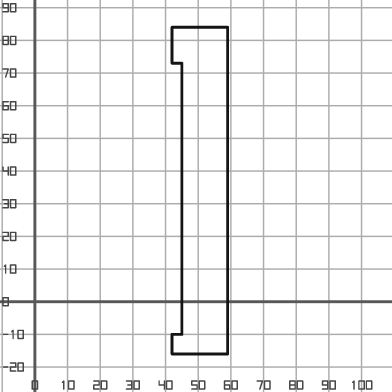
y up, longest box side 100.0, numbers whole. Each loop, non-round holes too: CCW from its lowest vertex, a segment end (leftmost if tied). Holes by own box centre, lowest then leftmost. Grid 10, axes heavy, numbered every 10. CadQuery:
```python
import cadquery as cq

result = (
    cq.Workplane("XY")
    .moveTo(42.0, -16.0)
    .lineTo(59.0, -16.0)
    .lineTo(59.0, 84.0)
    .lineTo(42.0, 84.0)
    .lineTo(42.0, 73.0)
    .lineTo(45.0, 73.0)
    .lineTo(45.0, -10.0)
    .lineTo(42.0, -10.0)
    .close()
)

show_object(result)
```